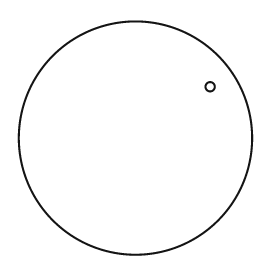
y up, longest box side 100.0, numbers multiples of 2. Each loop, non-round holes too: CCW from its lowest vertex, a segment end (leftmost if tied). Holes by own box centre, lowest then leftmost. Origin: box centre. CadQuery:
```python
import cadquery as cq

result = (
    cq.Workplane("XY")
    .moveTo(0.0, 0.0)
    .circle(50.0)
    .moveTo(32.0, 22.0)
    .circle(2.0)
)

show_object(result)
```